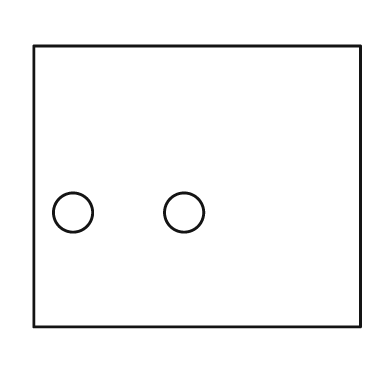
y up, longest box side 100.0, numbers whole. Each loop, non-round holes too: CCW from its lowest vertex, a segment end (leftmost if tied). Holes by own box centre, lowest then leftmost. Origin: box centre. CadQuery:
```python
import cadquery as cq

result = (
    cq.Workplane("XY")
    .moveTo(-50.0, -43.0)
    .lineTo(50.0, -43.0)
    .lineTo(50.0, 43.0)
    .lineTo(-50.0, 43.0)
    .close()
    .moveTo(-38.0, -8.0)
    .circle(6.0)
    .moveTo(-4.0, -8.0)
    .circle(6.0)
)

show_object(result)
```